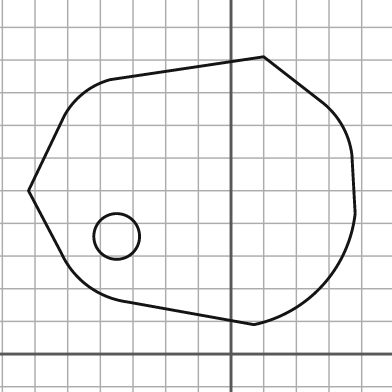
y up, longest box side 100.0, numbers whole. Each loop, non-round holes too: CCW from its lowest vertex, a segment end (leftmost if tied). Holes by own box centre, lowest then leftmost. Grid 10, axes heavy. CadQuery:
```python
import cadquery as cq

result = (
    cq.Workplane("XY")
    .moveTo(7.0, 9.0)
    .threePointArc((28.0, 21.0), (38.0, 43.0))
    .lineTo(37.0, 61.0)
    .threePointArc((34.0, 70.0), (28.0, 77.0))
    .lineTo(10.0, 91.0)
    .lineTo(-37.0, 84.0)
    .threePointArc((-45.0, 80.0), (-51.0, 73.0))
    .lineTo(-62.0, 50.0)
    .lineTo(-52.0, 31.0)
    .threePointArc((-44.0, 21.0), (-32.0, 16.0))
    .close()
    .moveTo(-35.0, 36.0)
    .circle(7.0)
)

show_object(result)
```